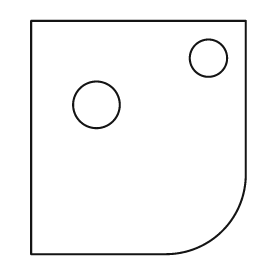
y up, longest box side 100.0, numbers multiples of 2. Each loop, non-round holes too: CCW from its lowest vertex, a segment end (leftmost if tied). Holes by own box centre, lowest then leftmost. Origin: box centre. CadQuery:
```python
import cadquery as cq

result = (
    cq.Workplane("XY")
    .moveTo(-46.0, -50.0)
    .lineTo(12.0, -50.0)
    .threePointArc((36.0, -40.0), (46.0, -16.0))
    .lineTo(46.0, 50.0)
    .lineTo(-46.0, 50.0)
    .close()
    .moveTo(-18.0, 14.0)
    .circle(10.0)
    .moveTo(30.0, 34.0)
    .circle(8.0)
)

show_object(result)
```